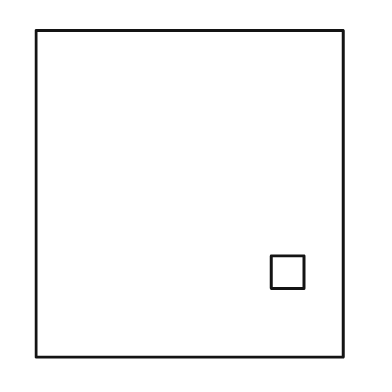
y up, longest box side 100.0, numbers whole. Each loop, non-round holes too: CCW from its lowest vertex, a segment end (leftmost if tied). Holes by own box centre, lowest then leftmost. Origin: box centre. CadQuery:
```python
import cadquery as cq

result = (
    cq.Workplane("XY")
    .moveTo(-47.0, -50.0)
    .lineTo(47.0, -50.0)
    .lineTo(47.0, 50.0)
    .lineTo(-47.0, 50.0)
    .close()
    .moveTo(25.0, -29.0)
    .lineTo(35.0, -29.0)
    .lineTo(35.0, -19.0)
    .lineTo(25.0, -19.0)
    .close()
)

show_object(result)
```